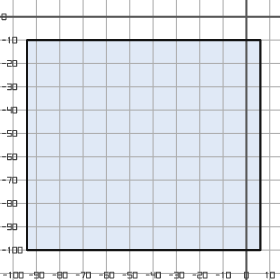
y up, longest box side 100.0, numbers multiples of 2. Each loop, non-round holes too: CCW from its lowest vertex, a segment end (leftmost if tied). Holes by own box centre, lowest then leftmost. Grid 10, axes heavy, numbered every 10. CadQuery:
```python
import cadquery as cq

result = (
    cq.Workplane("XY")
    .moveTo(-94.0, -100.0)
    .lineTo(6.0, -100.0)
    .lineTo(6.0, -10.0)
    .lineTo(-94.0, -10.0)
    .close()
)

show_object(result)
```